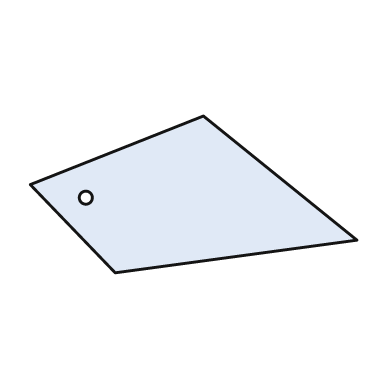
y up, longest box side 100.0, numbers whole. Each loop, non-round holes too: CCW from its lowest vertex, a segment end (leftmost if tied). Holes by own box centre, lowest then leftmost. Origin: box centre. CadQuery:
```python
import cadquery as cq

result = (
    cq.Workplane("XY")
    .moveTo(-24.0, -24.0)
    .lineTo(50.0, -14.0)
    .lineTo(3.0, 24.0)
    .lineTo(-50.0, 3.0)
    .close()
    .moveTo(-33.0, -1.0)
    .circle(2.0)
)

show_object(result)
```